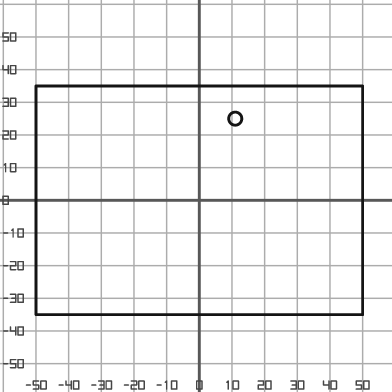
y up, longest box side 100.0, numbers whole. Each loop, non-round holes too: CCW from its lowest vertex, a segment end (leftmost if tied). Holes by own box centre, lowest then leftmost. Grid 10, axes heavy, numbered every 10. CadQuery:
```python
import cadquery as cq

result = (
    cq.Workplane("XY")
    .moveTo(-50.0, -35.0)
    .lineTo(50.0, -35.0)
    .lineTo(50.0, 35.0)
    .lineTo(-50.0, 35.0)
    .close()
    .moveTo(11.0, 25.0)
    .circle(2.0)
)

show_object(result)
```